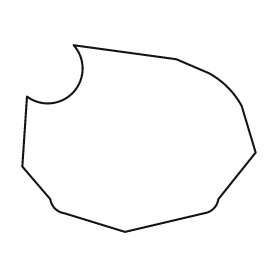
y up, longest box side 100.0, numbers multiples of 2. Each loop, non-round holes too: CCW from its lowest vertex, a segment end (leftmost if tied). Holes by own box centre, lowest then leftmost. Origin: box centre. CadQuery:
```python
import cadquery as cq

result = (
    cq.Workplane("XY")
    .moveTo(-6.0, -40.0)
    .lineTo(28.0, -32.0)
    .threePointArc((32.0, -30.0), (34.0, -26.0))
    .lineTo(50.0, -6.0)
    .lineTo(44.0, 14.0)
    .threePointArc((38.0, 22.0), (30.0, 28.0))
    .lineTo(16.0, 34.0)
    .lineTo(-28.0, 40.0)
    .threePointArc((-28.0, 20.0), (-48.0, 18.0))
    .lineTo(-50.0, -12.0)
    .lineTo(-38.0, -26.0)
    .threePointArc((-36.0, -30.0), (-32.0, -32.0))
    .close()
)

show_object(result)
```